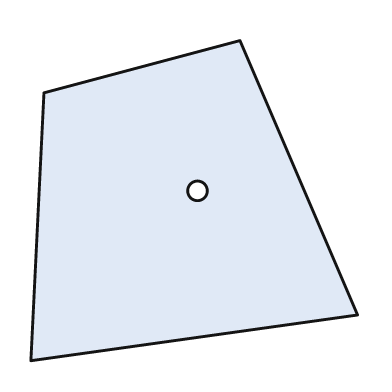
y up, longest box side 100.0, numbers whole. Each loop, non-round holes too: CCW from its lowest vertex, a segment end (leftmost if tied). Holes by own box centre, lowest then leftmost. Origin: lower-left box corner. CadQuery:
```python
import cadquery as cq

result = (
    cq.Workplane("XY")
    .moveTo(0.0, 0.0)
    .lineTo(100.0, 14.0)
    .lineTo(64.0, 98.0)
    .lineTo(4.0, 82.0)
    .close()
    .moveTo(51.0, 52.0)
    .circle(3.0)
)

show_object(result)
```